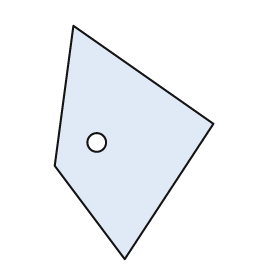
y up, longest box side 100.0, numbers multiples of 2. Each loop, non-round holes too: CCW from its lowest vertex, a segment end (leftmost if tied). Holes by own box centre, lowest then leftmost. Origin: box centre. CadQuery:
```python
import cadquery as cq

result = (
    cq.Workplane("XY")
    .moveTo(-4.0, -50.0)
    .lineTo(34.0, 8.0)
    .lineTo(-26.0, 50.0)
    .lineTo(-34.0, -10.0)
    .close()
    .moveTo(-16.0, 0.0)
    .circle(4.0)
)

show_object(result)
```